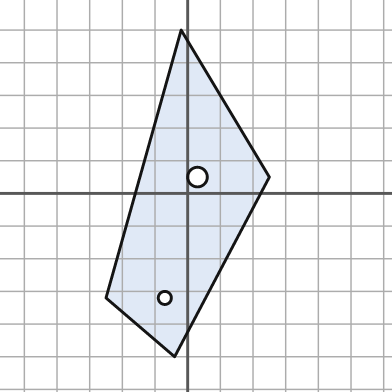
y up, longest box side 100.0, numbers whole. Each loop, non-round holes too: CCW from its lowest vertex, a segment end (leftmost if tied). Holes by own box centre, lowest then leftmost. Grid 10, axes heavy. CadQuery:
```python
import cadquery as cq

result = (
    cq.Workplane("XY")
    .moveTo(-4.0, -50.0)
    .lineTo(25.0, 5.0)
    .lineTo(-2.0, 50.0)
    .lineTo(-25.0, -32.0)
    .close()
    .moveTo(-7.0, -32.0)
    .circle(2.0)
    .moveTo(3.0, 5.0)
    .circle(3.0)
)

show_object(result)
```